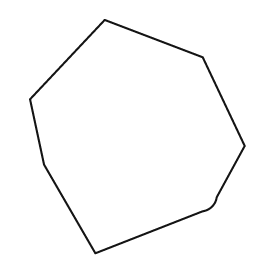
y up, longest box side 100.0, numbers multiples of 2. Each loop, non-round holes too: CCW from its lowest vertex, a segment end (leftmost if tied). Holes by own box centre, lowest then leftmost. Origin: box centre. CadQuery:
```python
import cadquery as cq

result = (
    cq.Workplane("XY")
    .moveTo(-18.0, -50.0)
    .lineTo(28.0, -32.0)
    .threePointArc((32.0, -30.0), (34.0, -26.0))
    .lineTo(46.0, -4.0)
    .lineTo(28.0, 34.0)
    .lineTo(-14.0, 50.0)
    .lineTo(-46.0, 16.0)
    .lineTo(-40.0, -12.0)
    .close()
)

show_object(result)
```